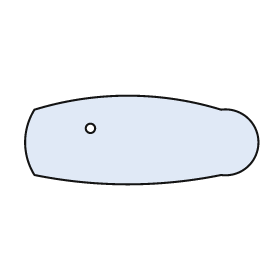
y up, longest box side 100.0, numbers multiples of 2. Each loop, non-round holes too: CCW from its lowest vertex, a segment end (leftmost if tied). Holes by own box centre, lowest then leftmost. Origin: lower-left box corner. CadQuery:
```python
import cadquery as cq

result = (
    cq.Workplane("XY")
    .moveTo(4.0, 4.0)
    .threePointArc((44.0, 0.0), (84.0, 4.0))
    .threePointArc((100.0, 18.0), (84.0, 32.0))
    .threePointArc((44.0, 38.0), (4.0, 32.0))
    .threePointArc((0.0, 18.0), (4.0, 4.0))
    .close()
    .moveTo(28.0, 24.0)
    .circle(2.0)
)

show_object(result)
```